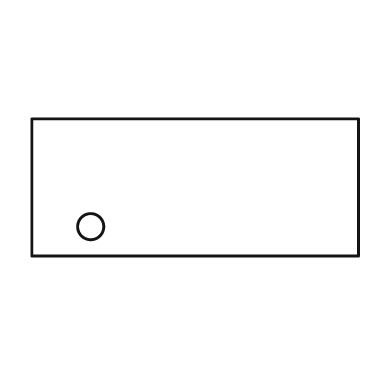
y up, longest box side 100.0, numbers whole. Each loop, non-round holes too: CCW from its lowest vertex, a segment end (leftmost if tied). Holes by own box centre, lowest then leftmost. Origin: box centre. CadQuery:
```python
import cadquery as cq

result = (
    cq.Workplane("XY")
    .moveTo(-50.0, -21.0)
    .lineTo(50.0, -21.0)
    .lineTo(50.0, 21.0)
    .lineTo(-50.0, 21.0)
    .close()
    .moveTo(-32.0, -12.0)
    .circle(4.0)
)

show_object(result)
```